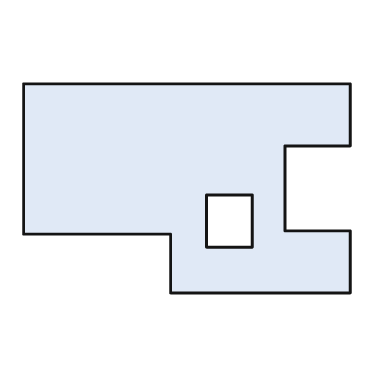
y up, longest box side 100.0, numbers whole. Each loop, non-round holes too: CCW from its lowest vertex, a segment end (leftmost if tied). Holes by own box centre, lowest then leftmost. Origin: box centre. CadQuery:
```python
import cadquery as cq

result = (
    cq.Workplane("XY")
    .moveTo(-5.0, -32.0)
    .lineTo(50.0, -32.0)
    .lineTo(50.0, -13.0)
    .lineTo(30.0, -13.0)
    .lineTo(30.0, 13.0)
    .lineTo(50.0, 13.0)
    .lineTo(50.0, 32.0)
    .lineTo(-50.0, 32.0)
    .lineTo(-50.0, -14.0)
    .lineTo(-5.0, -14.0)
    .close()
    .moveTo(6.0, -18.0)
    .lineTo(20.0, -18.0)
    .lineTo(20.0, -2.0)
    .lineTo(6.0, -2.0)
    .close()
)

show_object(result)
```